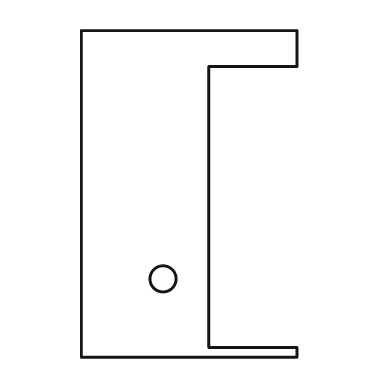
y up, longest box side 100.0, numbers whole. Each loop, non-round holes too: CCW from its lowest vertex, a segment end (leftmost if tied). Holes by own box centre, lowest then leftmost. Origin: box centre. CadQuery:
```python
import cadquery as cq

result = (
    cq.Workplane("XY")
    .moveTo(-33.0, -50.0)
    .lineTo(33.0, -50.0)
    .lineTo(33.0, -47.0)
    .lineTo(6.0, -47.0)
    .lineTo(6.0, 39.0)
    .lineTo(33.0, 39.0)
    .lineTo(33.0, 50.0)
    .lineTo(-33.0, 50.0)
    .close()
    .moveTo(-8.0, -26.0)
    .circle(4.0)
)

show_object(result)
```